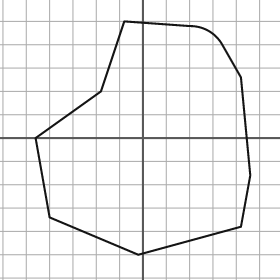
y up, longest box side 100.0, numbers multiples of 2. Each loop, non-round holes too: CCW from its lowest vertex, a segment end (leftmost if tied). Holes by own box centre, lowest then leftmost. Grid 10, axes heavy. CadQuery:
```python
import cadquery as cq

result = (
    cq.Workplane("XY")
    .moveTo(-2.0, -50.0)
    .lineTo(42.0, -38.0)
    .lineTo(46.0, -16.0)
    .lineTo(42.0, 26.0)
    .lineTo(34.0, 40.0)
    .threePointArc((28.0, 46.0), (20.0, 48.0))
    .lineTo(-8.0, 50.0)
    .lineTo(-18.0, 20.0)
    .lineTo(-46.0, 0.0)
    .lineTo(-40.0, -34.0)
    .close()
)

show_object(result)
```